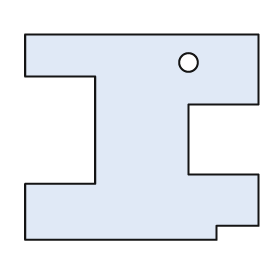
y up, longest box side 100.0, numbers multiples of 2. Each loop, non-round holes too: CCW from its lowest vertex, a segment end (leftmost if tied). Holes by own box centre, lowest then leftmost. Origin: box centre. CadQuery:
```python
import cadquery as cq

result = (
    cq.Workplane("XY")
    .moveTo(-50.0, -44.0)
    .lineTo(32.0, -44.0)
    .lineTo(32.0, -38.0)
    .lineTo(50.0, -38.0)
    .lineTo(50.0, -16.0)
    .lineTo(20.0, -16.0)
    .lineTo(20.0, 14.0)
    .lineTo(50.0, 14.0)
    .lineTo(50.0, 44.0)
    .lineTo(-50.0, 44.0)
    .lineTo(-50.0, 26.0)
    .lineTo(-20.0, 26.0)
    .lineTo(-20.0, -20.0)
    .lineTo(-50.0, -20.0)
    .close()
    .moveTo(20.0, 32.0)
    .circle(4.0)
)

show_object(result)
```